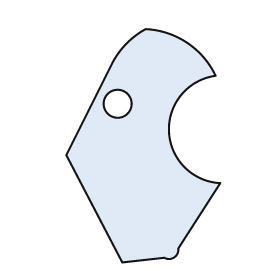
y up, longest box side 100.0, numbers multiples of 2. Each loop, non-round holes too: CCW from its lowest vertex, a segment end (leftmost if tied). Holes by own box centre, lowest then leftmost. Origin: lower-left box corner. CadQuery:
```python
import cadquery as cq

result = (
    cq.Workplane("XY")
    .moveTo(24.0, 0.0)
    .lineTo(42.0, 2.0)
    .threePointArc((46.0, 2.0), (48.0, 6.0))
    .lineTo(66.0, 34.0)
    .threePointArc((44.0, 56.0), (64.0, 80.0))
    .threePointArc((52.0, 94.0), (34.0, 100.0))
    .threePointArc((26.0, 94.0), (20.0, 86.0))
    .lineTo(0.0, 46.0)
    .close()
    .moveTo(22.0, 68.0)
    .circle(6.0)
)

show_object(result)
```